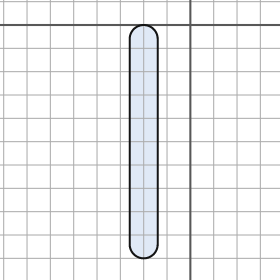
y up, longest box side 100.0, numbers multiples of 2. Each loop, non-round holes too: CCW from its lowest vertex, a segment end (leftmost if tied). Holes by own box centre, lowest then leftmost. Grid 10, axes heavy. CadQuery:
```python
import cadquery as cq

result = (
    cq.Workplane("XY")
    .moveTo(-26.0, -94.0)
    .threePointArc((-20.0, -100.0), (-14.0, -94.0))
    .lineTo(-14.0, -6.0)
    .threePointArc((-20.0, 0.0), (-26.0, -6.0))
    .close()
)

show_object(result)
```